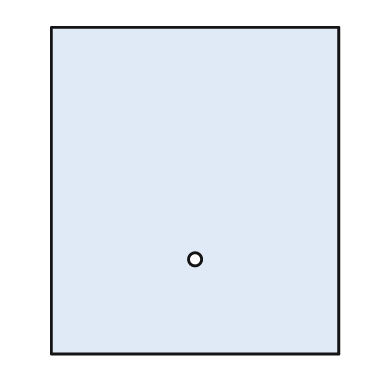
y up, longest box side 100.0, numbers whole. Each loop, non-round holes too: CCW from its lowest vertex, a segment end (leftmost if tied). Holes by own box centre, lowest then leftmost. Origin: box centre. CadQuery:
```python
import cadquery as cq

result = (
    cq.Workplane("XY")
    .moveTo(-44.0, -50.0)
    .lineTo(44.0, -50.0)
    .lineTo(44.0, 50.0)
    .lineTo(-44.0, 50.0)
    .close()
    .moveTo(0.0, -21.0)
    .circle(2.0)
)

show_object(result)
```